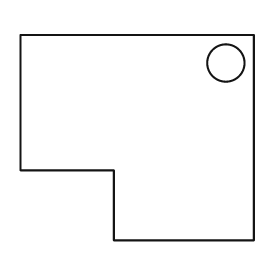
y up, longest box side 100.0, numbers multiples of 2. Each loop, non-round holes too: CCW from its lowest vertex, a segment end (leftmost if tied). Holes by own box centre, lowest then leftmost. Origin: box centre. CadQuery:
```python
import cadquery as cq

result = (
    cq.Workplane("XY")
    .moveTo(-10.0, -44.0)
    .lineTo(50.0, -44.0)
    .lineTo(50.0, 44.0)
    .lineTo(-50.0, 44.0)
    .lineTo(-50.0, -14.0)
    .lineTo(-10.0, -14.0)
    .close()
    .moveTo(38.0, 32.0)
    .circle(8.0)
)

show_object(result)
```